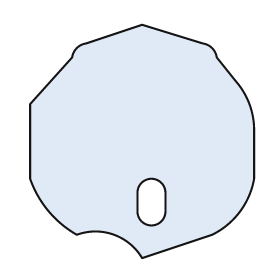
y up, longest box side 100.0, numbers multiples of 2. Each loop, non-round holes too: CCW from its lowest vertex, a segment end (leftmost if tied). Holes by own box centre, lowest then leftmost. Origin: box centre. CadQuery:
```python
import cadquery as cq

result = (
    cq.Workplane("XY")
    .moveTo(0.0, -50.0)
    .lineTo(30.0, -40.0)
    .threePointArc((42.0, -30.0), (48.0, -16.0))
    .lineTo(48.0, 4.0)
    .threePointArc((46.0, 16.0), (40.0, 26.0))
    .lineTo(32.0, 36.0)
    .threePointArc((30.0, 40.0), (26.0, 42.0))
    .lineTo(0.0, 50.0)
    .lineTo(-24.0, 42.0)
    .threePointArc((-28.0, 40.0), (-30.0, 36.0))
    .lineTo(-48.0, 16.0)
    .lineTo(-48.0, -16.0)
    .threePointArc((-40.0, -30.0), (-28.0, -40.0))
    .threePointArc((-12.0, -40.0), (0.0, -50.0))
    .close()
    .moveTo(-2.0, -30.0)
    .threePointArc((4.0, -36.0), (10.0, -30.0))
    .lineTo(10.0, -22.0)
    .threePointArc((4.0, -16.0), (-2.0, -22.0))
    .close()
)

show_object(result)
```